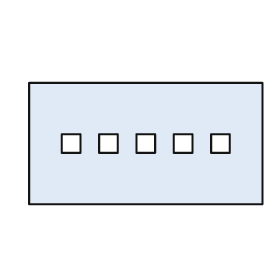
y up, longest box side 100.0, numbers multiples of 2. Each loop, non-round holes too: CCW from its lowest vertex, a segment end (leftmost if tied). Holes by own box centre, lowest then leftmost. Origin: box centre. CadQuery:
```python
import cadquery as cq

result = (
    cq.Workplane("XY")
    .moveTo(-50.0, -26.0)
    .lineTo(50.0, -26.0)
    .lineTo(50.0, 26.0)
    .lineTo(-50.0, 26.0)
    .close()
    .moveTo(-36.0, -4.0)
    .lineTo(-28.0, -4.0)
    .lineTo(-28.0, 4.0)
    .lineTo(-36.0, 4.0)
    .close()
    .moveTo(-20.0, -4.0)
    .lineTo(-12.0, -4.0)
    .lineTo(-12.0, 4.0)
    .lineTo(-20.0, 4.0)
    .close()
    .moveTo(-4.0, -4.0)
    .lineTo(4.0, -4.0)
    .lineTo(4.0, 4.0)
    .lineTo(-4.0, 4.0)
    .close()
    .moveTo(12.0, -4.0)
    .lineTo(20.0, -4.0)
    .lineTo(20.0, 4.0)
    .lineTo(12.0, 4.0)
    .close()
    .moveTo(28.0, -4.0)
    .lineTo(36.0, -4.0)
    .lineTo(36.0, 4.0)
    .lineTo(28.0, 4.0)
    .close()
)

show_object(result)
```